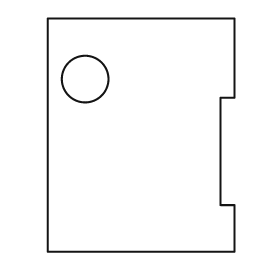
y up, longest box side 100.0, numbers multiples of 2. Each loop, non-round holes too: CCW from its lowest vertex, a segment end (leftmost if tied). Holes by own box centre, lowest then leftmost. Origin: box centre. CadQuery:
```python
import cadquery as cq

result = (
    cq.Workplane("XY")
    .moveTo(-40.0, -50.0)
    .lineTo(40.0, -50.0)
    .lineTo(40.0, -30.0)
    .lineTo(34.0, -30.0)
    .lineTo(34.0, 16.0)
    .lineTo(40.0, 16.0)
    .lineTo(40.0, 50.0)
    .lineTo(-40.0, 50.0)
    .close()
    .moveTo(-24.0, 24.0)
    .circle(10.0)
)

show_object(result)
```